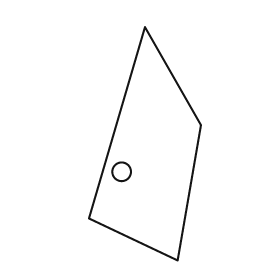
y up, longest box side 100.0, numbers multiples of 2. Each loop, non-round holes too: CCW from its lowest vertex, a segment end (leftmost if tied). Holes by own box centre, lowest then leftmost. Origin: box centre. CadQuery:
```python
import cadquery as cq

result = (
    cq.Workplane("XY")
    .moveTo(14.0, -50.0)
    .lineTo(24.0, 8.0)
    .lineTo(0.0, 50.0)
    .lineTo(-24.0, -32.0)
    .close()
    .moveTo(-10.0, -12.0)
    .circle(4.0)
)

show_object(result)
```